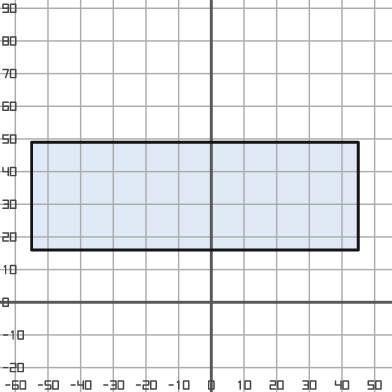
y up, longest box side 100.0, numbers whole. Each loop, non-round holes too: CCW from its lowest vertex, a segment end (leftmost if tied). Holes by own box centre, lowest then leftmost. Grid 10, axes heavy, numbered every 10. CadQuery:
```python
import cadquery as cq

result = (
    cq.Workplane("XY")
    .moveTo(-55.0, 16.0)
    .lineTo(45.0, 16.0)
    .lineTo(45.0, 49.0)
    .lineTo(-55.0, 49.0)
    .close()
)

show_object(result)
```